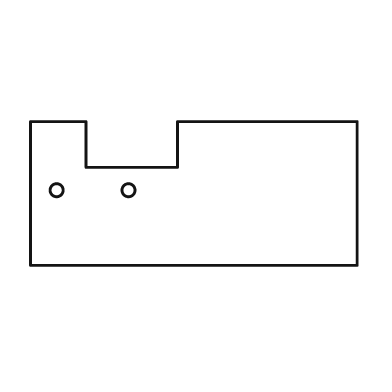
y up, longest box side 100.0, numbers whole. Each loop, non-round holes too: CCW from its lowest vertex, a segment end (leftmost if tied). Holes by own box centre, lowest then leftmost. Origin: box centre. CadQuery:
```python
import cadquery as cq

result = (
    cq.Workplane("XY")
    .moveTo(-50.0, -22.0)
    .lineTo(50.0, -22.0)
    .lineTo(50.0, 22.0)
    .lineTo(-5.0, 22.0)
    .lineTo(-5.0, 8.0)
    .lineTo(-33.0, 8.0)
    .lineTo(-33.0, 22.0)
    .lineTo(-50.0, 22.0)
    .close()
    .moveTo(-42.0, 1.0)
    .circle(2.0)
    .moveTo(-20.0, 1.0)
    .circle(2.0)
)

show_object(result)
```